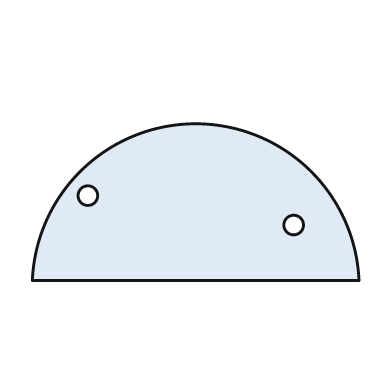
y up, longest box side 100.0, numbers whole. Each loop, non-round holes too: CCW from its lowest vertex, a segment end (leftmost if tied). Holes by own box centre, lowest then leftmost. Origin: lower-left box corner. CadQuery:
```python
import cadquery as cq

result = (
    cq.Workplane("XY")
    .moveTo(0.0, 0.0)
    .lineTo(100.0, 0.0)
    .threePointArc((50.0, 48.0), (0.0, 0.0))
    .close()
    .moveTo(80.0, 17.0)
    .circle(3.0)
    .moveTo(17.0, 26.0)
    .circle(3.0)
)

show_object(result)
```